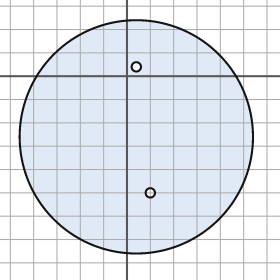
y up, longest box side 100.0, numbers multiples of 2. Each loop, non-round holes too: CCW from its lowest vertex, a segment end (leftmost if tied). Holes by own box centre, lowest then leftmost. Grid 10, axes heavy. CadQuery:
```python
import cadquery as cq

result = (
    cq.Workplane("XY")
    .moveTo(4.0, -26.0)
    .circle(50.0)
    .moveTo(10.0, -50.0)
    .circle(2.0)
    .moveTo(4.0, 4.0)
    .circle(2.0)
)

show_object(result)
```